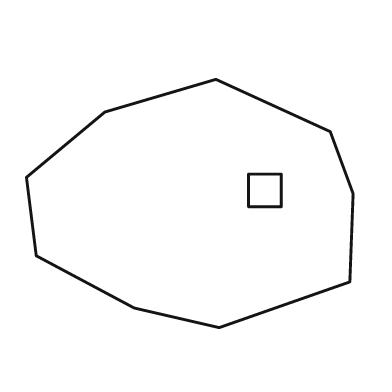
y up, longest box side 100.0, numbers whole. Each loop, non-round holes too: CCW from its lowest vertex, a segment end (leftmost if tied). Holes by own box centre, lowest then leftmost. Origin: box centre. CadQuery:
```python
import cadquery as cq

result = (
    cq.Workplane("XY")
    .moveTo(9.0, -38.0)
    .lineTo(49.0, -24.0)
    .lineTo(50.0, 3.0)
    .lineTo(43.0, 22.0)
    .lineTo(8.0, 38.0)
    .lineTo(-26.0, 28.0)
    .lineTo(-50.0, 8.0)
    .lineTo(-47.0, -16.0)
    .lineTo(-17.0, -32.0)
    .close()
    .moveTo(18.0, -1.0)
    .lineTo(28.0, -1.0)
    .lineTo(28.0, 9.0)
    .lineTo(18.0, 9.0)
    .close()
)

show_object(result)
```